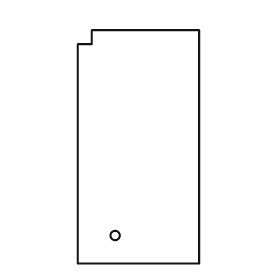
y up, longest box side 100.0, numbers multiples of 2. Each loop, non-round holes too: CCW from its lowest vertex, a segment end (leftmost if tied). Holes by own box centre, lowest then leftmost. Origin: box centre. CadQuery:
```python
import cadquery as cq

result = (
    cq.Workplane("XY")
    .moveTo(-26.0, -50.0)
    .lineTo(26.0, -50.0)
    .lineTo(26.0, 50.0)
    .lineTo(-20.0, 50.0)
    .lineTo(-20.0, 44.0)
    .lineTo(-26.0, 44.0)
    .close()
    .moveTo(-10.0, -38.0)
    .circle(2.0)
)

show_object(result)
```